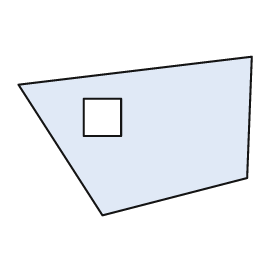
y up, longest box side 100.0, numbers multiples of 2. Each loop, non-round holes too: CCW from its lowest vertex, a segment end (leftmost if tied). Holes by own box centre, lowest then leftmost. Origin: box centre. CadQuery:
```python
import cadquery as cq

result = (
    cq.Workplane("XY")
    .moveTo(-14.0, -34.0)
    .lineTo(48.0, -18.0)
    .lineTo(50.0, 34.0)
    .lineTo(-50.0, 22.0)
    .close()
    .moveTo(-22.0, 0.0)
    .lineTo(-6.0, 0.0)
    .lineTo(-6.0, 16.0)
    .lineTo(-22.0, 16.0)
    .close()
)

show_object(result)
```